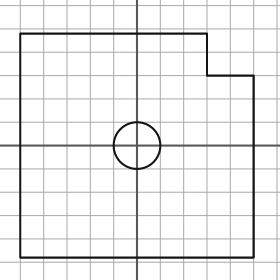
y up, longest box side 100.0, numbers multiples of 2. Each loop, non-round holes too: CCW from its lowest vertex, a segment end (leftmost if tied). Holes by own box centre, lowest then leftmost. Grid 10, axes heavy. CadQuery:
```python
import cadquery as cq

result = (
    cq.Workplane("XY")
    .moveTo(-50.0, -48.0)
    .lineTo(50.0, -48.0)
    .lineTo(50.0, 30.0)
    .lineTo(30.0, 30.0)
    .lineTo(30.0, 48.0)
    .lineTo(-50.0, 48.0)
    .close()
    .moveTo(0.0, 0.0)
    .circle(10.0)
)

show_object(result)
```